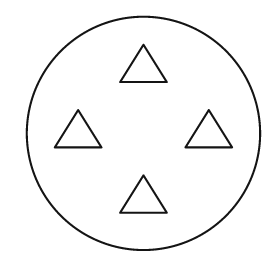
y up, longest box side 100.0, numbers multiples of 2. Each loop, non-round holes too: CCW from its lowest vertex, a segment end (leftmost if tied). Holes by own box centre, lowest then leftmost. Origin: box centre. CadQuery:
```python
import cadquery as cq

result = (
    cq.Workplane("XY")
    .moveTo(0.0, 0.0)
    .circle(50.0)
    .moveTo(-10.0, -34.0)
    .lineTo(10.0, -34.0)
    .lineTo(0.0, -18.0)
    .close()
    .moveTo(-38.0, -6.0)
    .lineTo(-18.0, -6.0)
    .lineTo(-28.0, 10.0)
    .close()
    .moveTo(18.0, -6.0)
    .lineTo(38.0, -6.0)
    .lineTo(28.0, 10.0)
    .close()
    .moveTo(-10.0, 22.0)
    .lineTo(10.0, 22.0)
    .lineTo(0.0, 38.0)
    .close()
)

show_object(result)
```